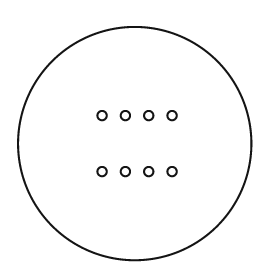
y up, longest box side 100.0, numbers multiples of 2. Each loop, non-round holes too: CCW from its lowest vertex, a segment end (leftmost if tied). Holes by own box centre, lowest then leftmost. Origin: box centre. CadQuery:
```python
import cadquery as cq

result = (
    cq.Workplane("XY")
    .moveTo(0.0, 0.0)
    .circle(50.0)
    .moveTo(-14.0, -12.0)
    .circle(2.0)
    .moveTo(-4.0, -12.0)
    .circle(2.0)
    .moveTo(6.0, -12.0)
    .circle(2.0)
    .moveTo(16.0, -12.0)
    .circle(2.0)
    .moveTo(-14.0, 12.0)
    .circle(2.0)
    .moveTo(-4.0, 12.0)
    .circle(2.0)
    .moveTo(6.0, 12.0)
    .circle(2.0)
    .moveTo(16.0, 12.0)
    .circle(2.0)
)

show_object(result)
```